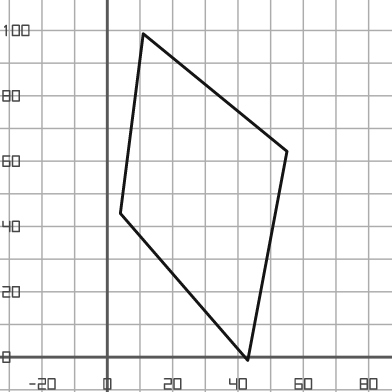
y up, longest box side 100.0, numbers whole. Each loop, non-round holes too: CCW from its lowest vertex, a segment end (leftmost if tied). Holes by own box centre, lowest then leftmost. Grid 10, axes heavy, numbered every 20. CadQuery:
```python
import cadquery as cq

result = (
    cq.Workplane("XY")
    .moveTo(43.0, -1.0)
    .lineTo(55.0, 63.0)
    .lineTo(11.0, 99.0)
    .lineTo(4.0, 44.0)
    .close()
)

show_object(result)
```